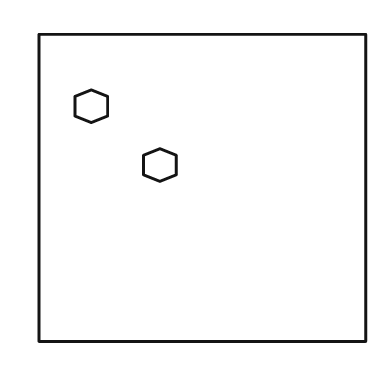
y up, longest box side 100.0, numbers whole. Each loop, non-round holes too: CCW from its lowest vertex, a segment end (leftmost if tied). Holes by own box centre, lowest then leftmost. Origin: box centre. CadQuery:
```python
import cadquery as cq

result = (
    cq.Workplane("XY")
    .moveTo(-50.0, -47.0)
    .lineTo(50.0, -47.0)
    .lineTo(50.0, 47.0)
    .lineTo(-50.0, 47.0)
    .close()
    .moveTo(-13.0, 2.0)
    .lineTo(-8.0, 4.0)
    .lineTo(-8.0, 10.0)
    .lineTo(-13.0, 12.0)
    .lineTo(-18.0, 10.0)
    .lineTo(-18.0, 4.0)
    .close()
    .moveTo(-34.0, 20.0)
    .lineTo(-29.0, 22.0)
    .lineTo(-29.0, 28.0)
    .lineTo(-34.0, 30.0)
    .lineTo(-39.0, 28.0)
    .lineTo(-39.0, 22.0)
    .close()
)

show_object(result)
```